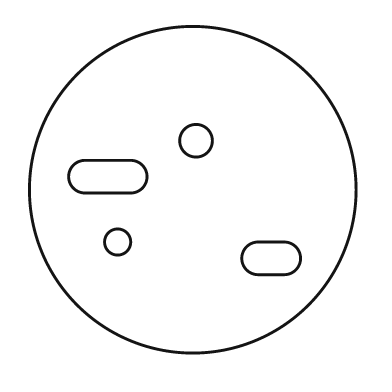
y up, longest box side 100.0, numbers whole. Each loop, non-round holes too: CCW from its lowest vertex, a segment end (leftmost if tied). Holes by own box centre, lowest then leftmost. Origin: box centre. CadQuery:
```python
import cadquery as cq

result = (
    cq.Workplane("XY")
    .moveTo(0.0, 0.0)
    .circle(50.0)
    .moveTo(20.0, -26.0)
    .lineTo(28.0, -26.0)
    .threePointArc((33.0, -21.0), (28.0, -16.0))
    .lineTo(20.0, -16.0)
    .threePointArc((15.0, -21.0), (20.0, -26.0))
    .close()
    .moveTo(-23.0, -16.0)
    .circle(4.0)
    .moveTo(-33.0, -1.0)
    .lineTo(-19.0, -1.0)
    .threePointArc((-14.0, 4.0), (-19.0, 9.0))
    .lineTo(-33.0, 9.0)
    .threePointArc((-38.0, 4.0), (-33.0, -1.0))
    .close()
    .moveTo(1.0, 15.0)
    .circle(5.0)
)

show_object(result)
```